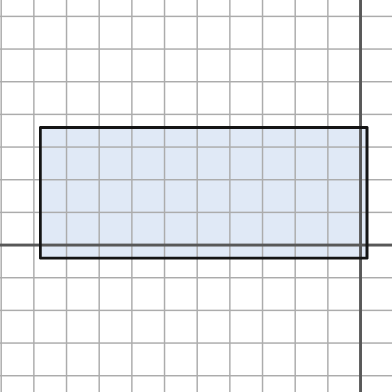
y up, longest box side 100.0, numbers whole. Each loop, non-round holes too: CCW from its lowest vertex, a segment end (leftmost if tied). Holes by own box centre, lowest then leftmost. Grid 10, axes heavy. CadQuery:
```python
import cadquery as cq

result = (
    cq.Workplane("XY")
    .moveTo(-98.0, -4.0)
    .lineTo(2.0, -4.0)
    .lineTo(2.0, 36.0)
    .lineTo(-98.0, 36.0)
    .close()
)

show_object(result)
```